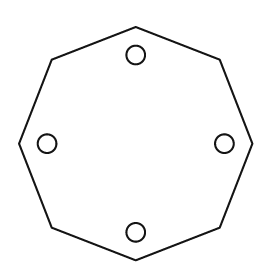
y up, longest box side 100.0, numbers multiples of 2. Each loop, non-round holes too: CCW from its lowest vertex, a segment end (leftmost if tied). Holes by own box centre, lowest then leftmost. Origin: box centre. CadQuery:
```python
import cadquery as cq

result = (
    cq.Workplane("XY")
    .moveTo(0.0, -50.0)
    .lineTo(36.0, -36.0)
    .lineTo(50.0, 0.0)
    .lineTo(36.0, 36.0)
    .lineTo(0.0, 50.0)
    .lineTo(-36.0, 36.0)
    .lineTo(-50.0, 0.0)
    .lineTo(-36.0, -36.0)
    .close()
    .moveTo(0.0, -38.0)
    .circle(4.0)
    .moveTo(-38.0, 0.0)
    .circle(4.0)
    .moveTo(38.0, 0.0)
    .circle(4.0)
    .moveTo(0.0, 38.0)
    .circle(4.0)
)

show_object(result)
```